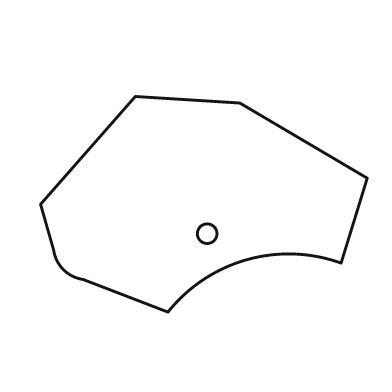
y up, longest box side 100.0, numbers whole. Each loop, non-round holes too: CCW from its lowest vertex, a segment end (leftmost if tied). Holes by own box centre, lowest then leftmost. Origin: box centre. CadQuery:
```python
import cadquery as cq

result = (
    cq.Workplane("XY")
    .moveTo(-11.0, -33.0)
    .threePointArc((13.0, -17.0), (42.0, -18.0))
    .lineTo(50.0, 8.0)
    .lineTo(11.0, 31.0)
    .lineTo(-21.0, 33.0)
    .lineTo(-50.0, 0.0)
    .lineTo(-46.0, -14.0)
    .threePointArc((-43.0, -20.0), (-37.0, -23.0))
    .close()
    .moveTo(1.0, -9.0)
    .circle(3.0)
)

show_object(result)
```